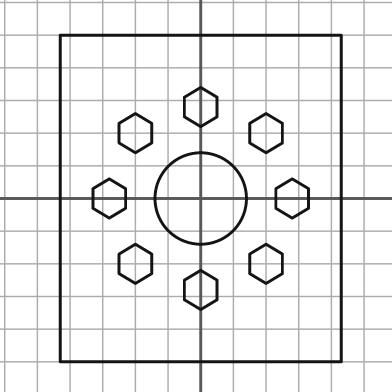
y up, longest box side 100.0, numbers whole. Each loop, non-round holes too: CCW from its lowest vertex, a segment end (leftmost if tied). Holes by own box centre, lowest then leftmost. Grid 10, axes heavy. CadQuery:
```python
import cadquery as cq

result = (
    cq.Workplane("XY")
    .moveTo(-43.0, -50.0)
    .lineTo(43.0, -50.0)
    .lineTo(43.0, 50.0)
    .lineTo(-43.0, 50.0)
    .close()
    .moveTo(0.0, -34.0)
    .lineTo(5.0, -31.0)
    .lineTo(5.0, -25.0)
    .lineTo(0.0, -22.0)
    .lineTo(-5.0, -25.0)
    .lineTo(-5.0, -31.0)
    .close()
    .moveTo(-20.0, -26.0)
    .lineTo(-15.0, -23.0)
    .lineTo(-15.0, -17.0)
    .lineTo(-20.0, -14.0)
    .lineTo(-25.0, -17.0)
    .lineTo(-25.0, -23.0)
    .close()
    .moveTo(20.0, -26.0)
    .lineTo(25.0, -23.0)
    .lineTo(25.0, -17.0)
    .lineTo(20.0, -14.0)
    .lineTo(15.0, -17.0)
    .lineTo(15.0, -23.0)
    .close()
    .moveTo(-28.0, -6.0)
    .lineTo(-23.0, -3.0)
    .lineTo(-23.0, 3.0)
    .lineTo(-28.0, 6.0)
    .lineTo(-33.0, 3.0)
    .lineTo(-33.0, -3.0)
    .close()
    .moveTo(0.0, 0.0)
    .circle(14.0)
    .moveTo(28.0, -6.0)
    .lineTo(33.0, -3.0)
    .lineTo(33.0, 3.0)
    .lineTo(28.0, 6.0)
    .lineTo(23.0, 3.0)
    .lineTo(23.0, -3.0)
    .close()
    .moveTo(-20.0, 14.0)
    .lineTo(-15.0, 17.0)
    .lineTo(-15.0, 23.0)
    .lineTo(-20.0, 26.0)
    .lineTo(-25.0, 23.0)
    .lineTo(-25.0, 17.0)
    .close()
    .moveTo(20.0, 14.0)
    .lineTo(25.0, 17.0)
    .lineTo(25.0, 23.0)
    .lineTo(20.0, 26.0)
    .lineTo(15.0, 23.0)
    .lineTo(15.0, 17.0)
    .close()
    .moveTo(0.0, 22.0)
    .lineTo(5.0, 25.0)
    .lineTo(5.0, 31.0)
    .lineTo(0.0, 34.0)
    .lineTo(-5.0, 31.0)
    .lineTo(-5.0, 25.0)
    .close()
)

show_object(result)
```